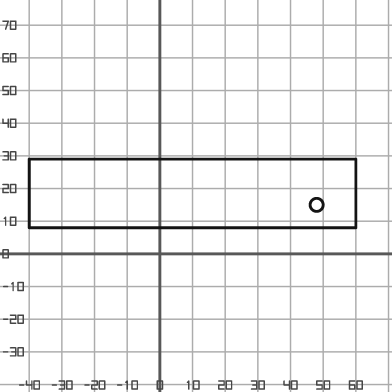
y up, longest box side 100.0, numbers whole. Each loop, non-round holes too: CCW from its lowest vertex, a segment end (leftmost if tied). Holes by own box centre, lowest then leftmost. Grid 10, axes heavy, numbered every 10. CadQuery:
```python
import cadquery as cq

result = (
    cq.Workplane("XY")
    .moveTo(-40.0, 8.0)
    .lineTo(60.0, 8.0)
    .lineTo(60.0, 29.0)
    .lineTo(-40.0, 29.0)
    .close()
    .moveTo(48.0, 15.0)
    .circle(2.0)
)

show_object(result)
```